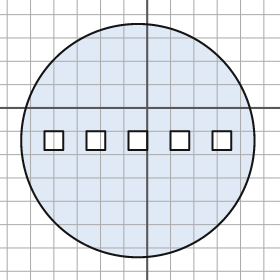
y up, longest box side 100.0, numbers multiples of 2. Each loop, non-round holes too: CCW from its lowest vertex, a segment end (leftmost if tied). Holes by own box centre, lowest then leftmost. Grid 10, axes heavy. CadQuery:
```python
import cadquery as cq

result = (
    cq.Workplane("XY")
    .moveTo(-4.0, -14.0)
    .circle(50.0)
    .moveTo(-44.0, -18.0)
    .lineTo(-36.0, -18.0)
    .lineTo(-36.0, -10.0)
    .lineTo(-44.0, -10.0)
    .close()
    .moveTo(-26.0, -18.0)
    .lineTo(-18.0, -18.0)
    .lineTo(-18.0, -10.0)
    .lineTo(-26.0, -10.0)
    .close()
    .moveTo(-8.0, -18.0)
    .lineTo(0.0, -18.0)
    .lineTo(0.0, -10.0)
    .lineTo(-8.0, -10.0)
    .close()
    .moveTo(10.0, -18.0)
    .lineTo(18.0, -18.0)
    .lineTo(18.0, -10.0)
    .lineTo(10.0, -10.0)
    .close()
    .moveTo(28.0, -18.0)
    .lineTo(36.0, -18.0)
    .lineTo(36.0, -10.0)
    .lineTo(28.0, -10.0)
    .close()
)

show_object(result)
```